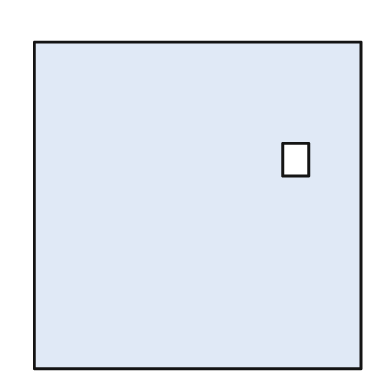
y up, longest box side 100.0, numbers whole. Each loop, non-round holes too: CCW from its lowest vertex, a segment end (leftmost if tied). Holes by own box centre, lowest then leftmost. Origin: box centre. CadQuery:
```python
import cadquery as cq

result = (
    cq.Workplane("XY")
    .moveTo(-50.0, -50.0)
    .lineTo(50.0, -50.0)
    .lineTo(50.0, 50.0)
    .lineTo(-50.0, 50.0)
    .close()
    .moveTo(26.0, 9.0)
    .lineTo(34.0, 9.0)
    .lineTo(34.0, 19.0)
    .lineTo(26.0, 19.0)
    .close()
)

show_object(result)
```